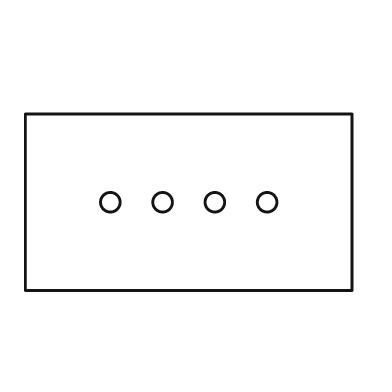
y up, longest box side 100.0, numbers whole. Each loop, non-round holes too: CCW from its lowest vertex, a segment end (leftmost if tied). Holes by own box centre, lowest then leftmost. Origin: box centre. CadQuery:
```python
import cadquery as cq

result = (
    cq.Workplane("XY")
    .moveTo(-50.0, -27.0)
    .lineTo(50.0, -27.0)
    .lineTo(50.0, 27.0)
    .lineTo(-50.0, 27.0)
    .close()
    .moveTo(-24.0, 0.0)
    .circle(3.0)
    .moveTo(-8.0, 0.0)
    .circle(3.0)
    .moveTo(8.0, 0.0)
    .circle(3.0)
    .moveTo(24.0, 0.0)
    .circle(3.0)
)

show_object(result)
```